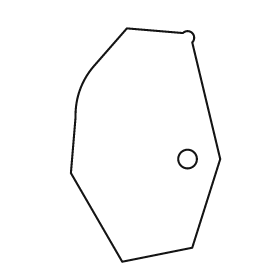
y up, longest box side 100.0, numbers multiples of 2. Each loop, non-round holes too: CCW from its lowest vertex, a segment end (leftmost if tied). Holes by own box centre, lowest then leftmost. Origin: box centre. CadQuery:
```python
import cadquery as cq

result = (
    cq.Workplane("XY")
    .moveTo(-10.0, -50.0)
    .lineTo(20.0, -44.0)
    .lineTo(32.0, -6.0)
    .lineTo(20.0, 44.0)
    .threePointArc((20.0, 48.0), (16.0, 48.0))
    .lineTo(-8.0, 50.0)
    .lineTo(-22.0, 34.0)
    .threePointArc((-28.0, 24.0), (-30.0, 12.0))
    .lineTo(-32.0, -12.0)
    .close()
    .moveTo(18.0, -6.0)
    .circle(4.0)
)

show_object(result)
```